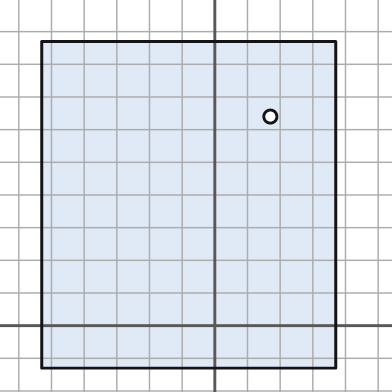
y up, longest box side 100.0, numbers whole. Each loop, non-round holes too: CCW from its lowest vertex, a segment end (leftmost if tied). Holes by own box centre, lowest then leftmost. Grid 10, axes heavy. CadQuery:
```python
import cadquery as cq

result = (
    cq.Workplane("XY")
    .moveTo(-53.0, -13.0)
    .lineTo(37.0, -13.0)
    .lineTo(37.0, 87.0)
    .lineTo(-53.0, 87.0)
    .close()
    .moveTo(17.0, 64.0)
    .circle(2.0)
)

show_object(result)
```